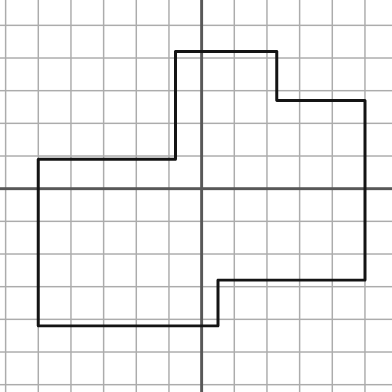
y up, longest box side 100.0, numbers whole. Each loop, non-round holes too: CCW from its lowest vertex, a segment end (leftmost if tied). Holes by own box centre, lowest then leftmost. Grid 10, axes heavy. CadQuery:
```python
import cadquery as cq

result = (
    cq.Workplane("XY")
    .moveTo(-50.0, -42.0)
    .lineTo(5.0, -42.0)
    .lineTo(5.0, -28.0)
    .lineTo(50.0, -28.0)
    .lineTo(50.0, 27.0)
    .lineTo(23.0, 27.0)
    .lineTo(23.0, 42.0)
    .lineTo(-8.0, 42.0)
    .lineTo(-8.0, 9.0)
    .lineTo(-50.0, 9.0)
    .close()
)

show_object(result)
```